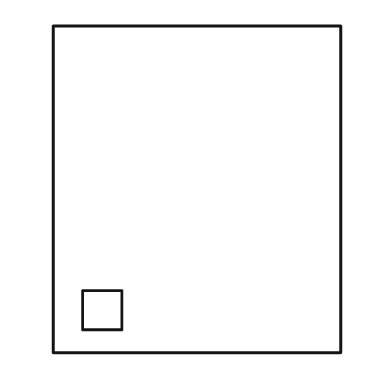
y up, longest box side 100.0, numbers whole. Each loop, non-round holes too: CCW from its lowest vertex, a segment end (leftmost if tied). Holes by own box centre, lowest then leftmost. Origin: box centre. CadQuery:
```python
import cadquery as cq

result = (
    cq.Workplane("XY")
    .moveTo(-44.0, -50.0)
    .lineTo(44.0, -50.0)
    .lineTo(44.0, 50.0)
    .lineTo(-44.0, 50.0)
    .close()
    .moveTo(-35.0, -43.0)
    .lineTo(-23.0, -43.0)
    .lineTo(-23.0, -31.0)
    .lineTo(-35.0, -31.0)
    .close()
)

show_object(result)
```